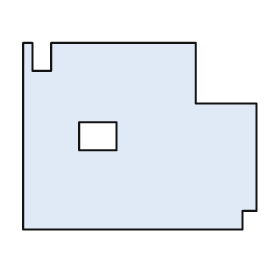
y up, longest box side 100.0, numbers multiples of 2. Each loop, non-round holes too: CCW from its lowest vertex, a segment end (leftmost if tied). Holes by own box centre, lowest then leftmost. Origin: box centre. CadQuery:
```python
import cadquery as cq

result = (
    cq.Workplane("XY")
    .moveTo(-50.0, -40.0)
    .lineTo(44.0, -40.0)
    .lineTo(44.0, -32.0)
    .lineTo(50.0, -32.0)
    .lineTo(50.0, 14.0)
    .lineTo(24.0, 14.0)
    .lineTo(24.0, 40.0)
    .lineTo(-38.0, 40.0)
    .lineTo(-38.0, 28.0)
    .lineTo(-46.0, 28.0)
    .lineTo(-46.0, 40.0)
    .lineTo(-50.0, 40.0)
    .close()
    .moveTo(-26.0, -6.0)
    .lineTo(-10.0, -6.0)
    .lineTo(-10.0, 6.0)
    .lineTo(-26.0, 6.0)
    .close()
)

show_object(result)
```